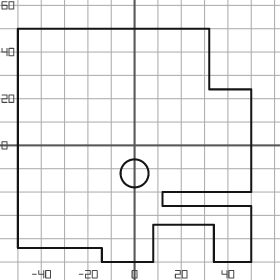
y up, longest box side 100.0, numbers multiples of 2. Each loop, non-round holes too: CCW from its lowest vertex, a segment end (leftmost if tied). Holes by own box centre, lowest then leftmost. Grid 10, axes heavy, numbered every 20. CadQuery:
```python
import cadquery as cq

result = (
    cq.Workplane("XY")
    .moveTo(-14.0, -50.0)
    .lineTo(8.0, -50.0)
    .lineTo(8.0, -34.0)
    .lineTo(34.0, -34.0)
    .lineTo(34.0, -50.0)
    .lineTo(50.0, -50.0)
    .lineTo(50.0, -26.0)
    .lineTo(12.0, -26.0)
    .lineTo(12.0, -20.0)
    .lineTo(50.0, -20.0)
    .lineTo(50.0, 24.0)
    .lineTo(32.0, 24.0)
    .lineTo(32.0, 50.0)
    .lineTo(-50.0, 50.0)
    .lineTo(-50.0, -44.0)
    .lineTo(-14.0, -44.0)
    .close()
    .moveTo(0.0, -12.0)
    .circle(6.0)
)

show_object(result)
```